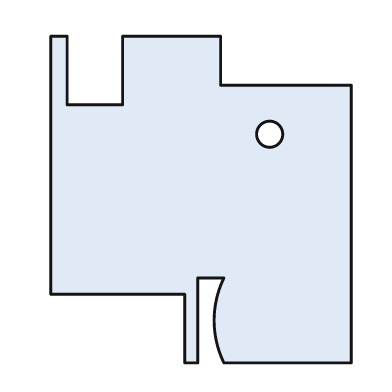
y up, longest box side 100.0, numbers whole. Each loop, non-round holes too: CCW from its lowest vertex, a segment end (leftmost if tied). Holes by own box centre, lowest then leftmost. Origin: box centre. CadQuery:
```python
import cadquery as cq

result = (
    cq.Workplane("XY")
    .moveTo(-5.0, -50.0)
    .lineTo(-1.0, -50.0)
    .lineTo(-1.0, -24.0)
    .lineTo(7.0, -24.0)
    .threePointArc((4.0, -37.0), (7.0, -50.0))
    .lineTo(46.0, -50.0)
    .lineTo(46.0, 35.0)
    .lineTo(6.0, 35.0)
    .lineTo(6.0, 50.0)
    .lineTo(-24.0, 50.0)
    .lineTo(-24.0, 29.0)
    .lineTo(-41.0, 29.0)
    .lineTo(-41.0, 50.0)
    .lineTo(-46.0, 50.0)
    .lineTo(-46.0, -29.0)
    .lineTo(-5.0, -29.0)
    .close()
    .moveTo(21.0, 20.0)
    .circle(4.0)
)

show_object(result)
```